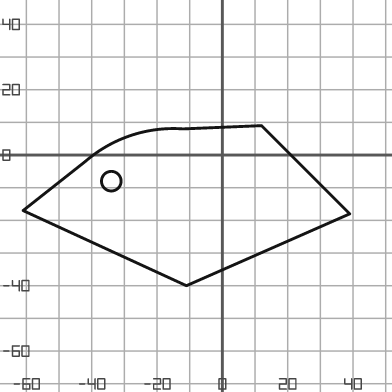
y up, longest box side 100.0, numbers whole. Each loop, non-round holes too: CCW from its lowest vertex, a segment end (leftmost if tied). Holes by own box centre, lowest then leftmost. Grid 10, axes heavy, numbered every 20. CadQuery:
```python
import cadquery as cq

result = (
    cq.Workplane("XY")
    .moveTo(-11.0, -40.0)
    .lineTo(39.0, -18.0)
    .lineTo(12.0, 9.0)
    .lineTo(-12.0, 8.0)
    .threePointArc((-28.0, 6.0), (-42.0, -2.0))
    .lineTo(-61.0, -17.0)
    .close()
    .moveTo(-34.0, -8.0)
    .circle(3.0)
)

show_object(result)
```